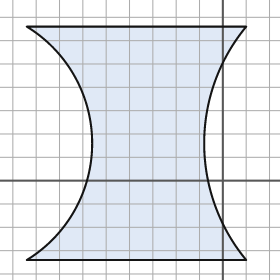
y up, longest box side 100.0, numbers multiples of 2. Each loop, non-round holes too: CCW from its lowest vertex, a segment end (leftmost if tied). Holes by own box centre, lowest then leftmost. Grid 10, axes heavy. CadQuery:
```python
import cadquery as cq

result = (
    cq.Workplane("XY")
    .moveTo(-84.0, -34.0)
    .lineTo(10.0, -34.0)
    .threePointArc((-8.0, 16.0), (10.0, 66.0))
    .lineTo(-84.0, 66.0)
    .threePointArc((-56.0, 16.0), (-84.0, -34.0))
    .close()
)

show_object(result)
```